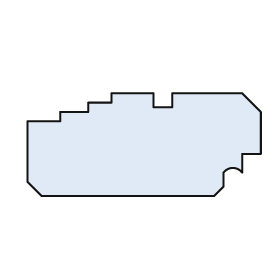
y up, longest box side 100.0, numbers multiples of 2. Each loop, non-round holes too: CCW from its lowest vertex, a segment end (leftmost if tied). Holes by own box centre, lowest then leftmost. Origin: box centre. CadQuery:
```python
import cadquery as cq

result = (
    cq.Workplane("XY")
    .moveTo(-44.0, -22.0)
    .lineTo(30.0, -22.0)
    .lineTo(34.0, -18.0)
    .lineTo(34.0, -12.0)
    .threePointArc((38.0, -10.0), (42.0, -12.0))
    .lineTo(42.0, -4.0)
    .lineTo(50.0, -4.0)
    .lineTo(50.0, 14.0)
    .lineTo(42.0, 22.0)
    .lineTo(12.0, 22.0)
    .lineTo(12.0, 16.0)
    .lineTo(4.0, 16.0)
    .lineTo(4.0, 22.0)
    .lineTo(-14.0, 22.0)
    .lineTo(-14.0, 18.0)
    .lineTo(-24.0, 18.0)
    .lineTo(-24.0, 14.0)
    .lineTo(-36.0, 14.0)
    .lineTo(-36.0, 10.0)
    .lineTo(-50.0, 10.0)
    .lineTo(-50.0, -16.0)
    .close()
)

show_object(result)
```